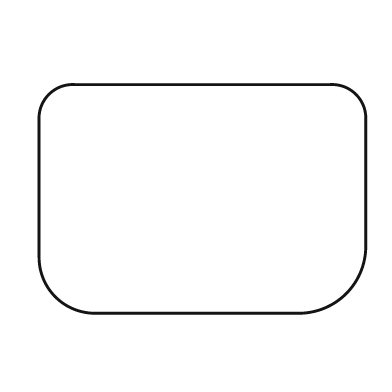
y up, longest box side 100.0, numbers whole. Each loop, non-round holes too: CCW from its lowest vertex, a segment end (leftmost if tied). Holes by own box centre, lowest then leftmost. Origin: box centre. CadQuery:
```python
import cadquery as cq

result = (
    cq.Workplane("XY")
    .moveTo(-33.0, -35.0)
    .lineTo(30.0, -35.0)
    .threePointArc((44.0, -29.0), (50.0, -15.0))
    .lineTo(50.0, 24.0)
    .threePointArc((47.0, 32.0), (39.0, 35.0))
    .lineTo(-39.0, 35.0)
    .threePointArc((-47.0, 32.0), (-50.0, 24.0))
    .lineTo(-50.0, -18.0)
    .threePointArc((-45.0, -30.0), (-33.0, -35.0))
    .close()
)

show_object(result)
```